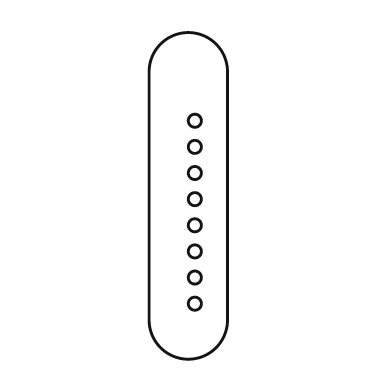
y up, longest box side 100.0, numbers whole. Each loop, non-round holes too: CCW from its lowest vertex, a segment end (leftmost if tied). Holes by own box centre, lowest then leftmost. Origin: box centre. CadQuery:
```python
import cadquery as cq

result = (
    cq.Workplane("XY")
    .moveTo(-12.0, -38.0)
    .threePointArc((0.0, -50.0), (12.0, -38.0))
    .lineTo(12.0, 38.0)
    .threePointArc((0.0, 50.0), (-12.0, 38.0))
    .close()
    .moveTo(2.0, -33.0)
    .circle(2.0)
    .moveTo(2.0, -25.0)
    .circle(2.0)
    .moveTo(2.0, -17.0)
    .circle(2.0)
    .moveTo(2.0, -9.0)
    .circle(2.0)
    .moveTo(2.0, -1.0)
    .circle(2.0)
    .moveTo(2.0, 7.0)
    .circle(2.0)
    .moveTo(2.0, 15.0)
    .circle(2.0)
    .moveTo(2.0, 23.0)
    .circle(2.0)
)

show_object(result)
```